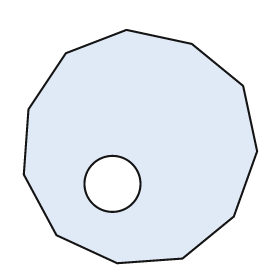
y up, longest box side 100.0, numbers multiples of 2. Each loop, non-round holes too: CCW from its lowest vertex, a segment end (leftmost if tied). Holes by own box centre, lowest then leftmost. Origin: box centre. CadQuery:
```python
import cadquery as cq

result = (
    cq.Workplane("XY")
    .moveTo(-10.0, -50.0)
    .lineTo(18.0, -48.0)
    .lineTo(40.0, -30.0)
    .lineTo(50.0, -2.0)
    .lineTo(44.0, 26.0)
    .lineTo(22.0, 44.0)
    .lineTo(-6.0, 50.0)
    .lineTo(-32.0, 40.0)
    .lineTo(-48.0, 16.0)
    .lineTo(-50.0, -12.0)
    .lineTo(-36.0, -38.0)
    .close()
    .moveTo(-12.0, -16.0)
    .circle(12.0)
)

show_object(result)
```